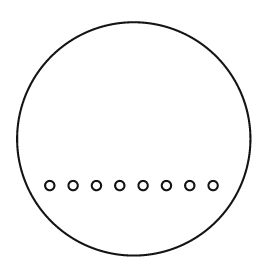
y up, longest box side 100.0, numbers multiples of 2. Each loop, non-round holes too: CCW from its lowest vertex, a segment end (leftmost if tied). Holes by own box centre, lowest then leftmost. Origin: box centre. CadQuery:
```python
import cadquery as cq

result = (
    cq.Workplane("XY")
    .moveTo(0.0, 0.0)
    .circle(50.0)
    .moveTo(-36.0, -20.0)
    .circle(2.0)
    .moveTo(-26.0, -20.0)
    .circle(2.0)
    .moveTo(-16.0, -20.0)
    .circle(2.0)
    .moveTo(-6.0, -20.0)
    .circle(2.0)
    .moveTo(4.0, -20.0)
    .circle(2.0)
    .moveTo(14.0, -20.0)
    .circle(2.0)
    .moveTo(24.0, -20.0)
    .circle(2.0)
    .moveTo(34.0, -20.0)
    .circle(2.0)
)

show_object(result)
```